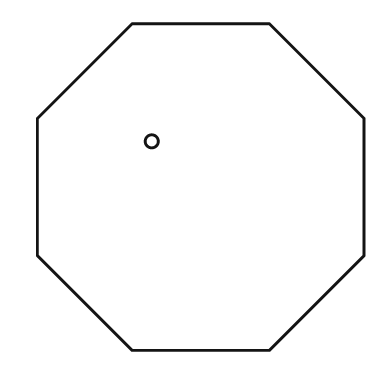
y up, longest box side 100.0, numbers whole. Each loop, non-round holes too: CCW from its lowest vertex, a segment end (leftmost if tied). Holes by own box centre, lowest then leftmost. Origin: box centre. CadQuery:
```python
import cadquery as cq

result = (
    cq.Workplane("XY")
    .moveTo(-21.0, -50.0)
    .lineTo(21.0, -50.0)
    .lineTo(50.0, -21.0)
    .lineTo(50.0, 21.0)
    .lineTo(21.0, 50.0)
    .lineTo(-21.0, 50.0)
    .lineTo(-50.0, 21.0)
    .lineTo(-50.0, -21.0)
    .close()
    .moveTo(-15.0, 14.0)
    .circle(2.0)
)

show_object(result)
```